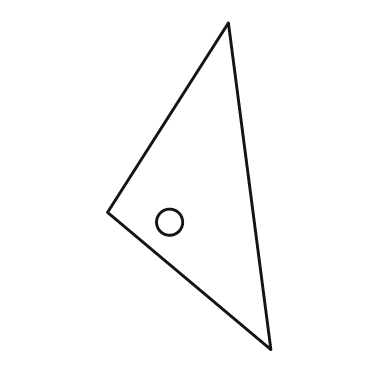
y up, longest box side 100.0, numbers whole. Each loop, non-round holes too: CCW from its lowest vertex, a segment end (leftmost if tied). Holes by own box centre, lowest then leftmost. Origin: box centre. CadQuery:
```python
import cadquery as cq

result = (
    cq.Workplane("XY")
    .moveTo(25.0, -50.0)
    .lineTo(12.0, 50.0)
    .lineTo(-25.0, -8.0)
    .close()
    .moveTo(-6.0, -11.0)
    .circle(4.0)
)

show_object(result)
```